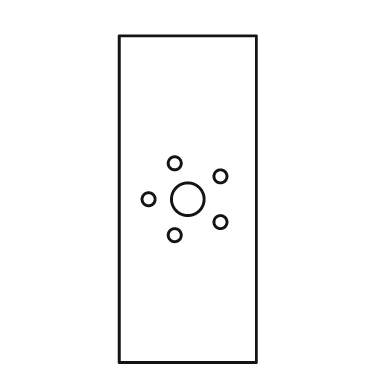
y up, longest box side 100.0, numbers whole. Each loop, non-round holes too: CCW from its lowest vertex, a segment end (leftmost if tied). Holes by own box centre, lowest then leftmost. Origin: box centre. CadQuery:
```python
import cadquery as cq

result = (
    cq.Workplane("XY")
    .moveTo(-21.0, -50.0)
    .lineTo(21.0, -50.0)
    .lineTo(21.0, 50.0)
    .lineTo(-21.0, 50.0)
    .close()
    .moveTo(-4.0, -11.0)
    .circle(2.0)
    .moveTo(10.0, -7.0)
    .circle(2.0)
    .moveTo(-12.0, 0.0)
    .circle(2.0)
    .moveTo(0.0, 0.0)
    .circle(5.0)
    .moveTo(10.0, 7.0)
    .circle(2.0)
    .moveTo(-4.0, 11.0)
    .circle(2.0)
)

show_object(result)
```